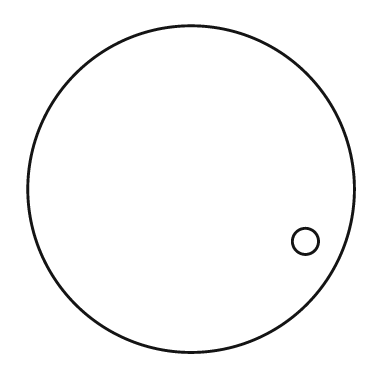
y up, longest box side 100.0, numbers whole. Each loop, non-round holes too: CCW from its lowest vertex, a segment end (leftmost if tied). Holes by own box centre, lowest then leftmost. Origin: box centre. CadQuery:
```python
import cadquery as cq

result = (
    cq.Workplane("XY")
    .moveTo(0.0, 0.0)
    .circle(50.0)
    .moveTo(35.0, -16.0)
    .circle(4.0)
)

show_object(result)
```